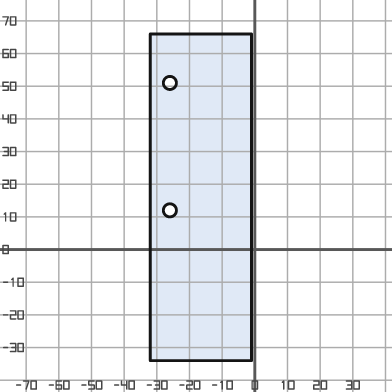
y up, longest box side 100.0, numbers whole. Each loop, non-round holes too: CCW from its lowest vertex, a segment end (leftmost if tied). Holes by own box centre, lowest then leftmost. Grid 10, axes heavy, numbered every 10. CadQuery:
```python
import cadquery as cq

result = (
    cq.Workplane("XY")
    .moveTo(-32.0, -34.0)
    .lineTo(-1.0, -34.0)
    .lineTo(-1.0, 66.0)
    .lineTo(-32.0, 66.0)
    .close()
    .moveTo(-26.0, 12.0)
    .circle(2.0)
    .moveTo(-26.0, 51.0)
    .circle(2.0)
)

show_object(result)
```